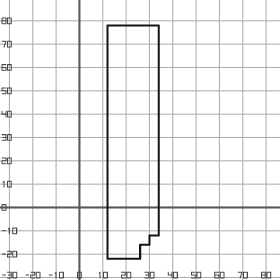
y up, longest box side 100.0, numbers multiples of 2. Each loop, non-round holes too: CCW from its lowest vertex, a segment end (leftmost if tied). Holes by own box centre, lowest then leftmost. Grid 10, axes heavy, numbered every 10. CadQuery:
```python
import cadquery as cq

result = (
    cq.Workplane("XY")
    .moveTo(12.0, -22.0)
    .lineTo(26.0, -22.0)
    .lineTo(26.0, -16.0)
    .lineTo(30.0, -16.0)
    .lineTo(30.0, -12.0)
    .lineTo(34.0, -12.0)
    .lineTo(34.0, 78.0)
    .lineTo(12.0, 78.0)
    .close()
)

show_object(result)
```